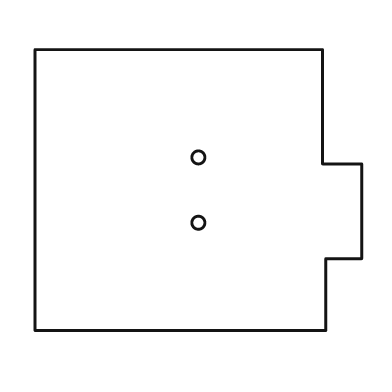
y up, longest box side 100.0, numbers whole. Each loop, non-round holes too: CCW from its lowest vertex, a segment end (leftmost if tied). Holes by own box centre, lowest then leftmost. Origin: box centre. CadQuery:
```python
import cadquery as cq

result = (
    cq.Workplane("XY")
    .moveTo(-50.0, -43.0)
    .lineTo(39.0, -43.0)
    .lineTo(39.0, -21.0)
    .lineTo(50.0, -21.0)
    .lineTo(50.0, 8.0)
    .lineTo(38.0, 8.0)
    .lineTo(38.0, 43.0)
    .lineTo(-50.0, 43.0)
    .close()
    .moveTo(0.0, -10.0)
    .circle(2.0)
    .moveTo(0.0, 10.0)
    .circle(2.0)
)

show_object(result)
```